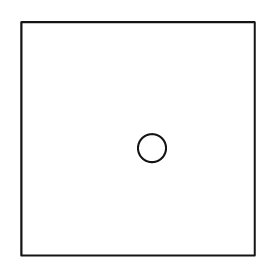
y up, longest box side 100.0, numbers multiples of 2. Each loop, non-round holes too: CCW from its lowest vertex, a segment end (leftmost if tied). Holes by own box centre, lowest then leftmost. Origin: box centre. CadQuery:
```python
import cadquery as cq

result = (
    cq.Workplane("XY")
    .moveTo(-50.0, -50.0)
    .lineTo(50.0, -50.0)
    .lineTo(50.0, 50.0)
    .lineTo(-50.0, 50.0)
    .close()
    .moveTo(6.0, -4.0)
    .circle(6.0)
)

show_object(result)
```